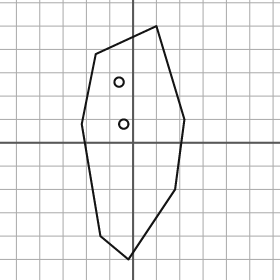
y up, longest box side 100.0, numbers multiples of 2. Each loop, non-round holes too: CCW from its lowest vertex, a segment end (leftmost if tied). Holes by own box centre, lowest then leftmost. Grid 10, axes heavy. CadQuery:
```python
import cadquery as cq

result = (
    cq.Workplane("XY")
    .moveTo(-2.0, -50.0)
    .lineTo(18.0, -20.0)
    .lineTo(22.0, 10.0)
    .lineTo(10.0, 50.0)
    .lineTo(-16.0, 38.0)
    .lineTo(-22.0, 8.0)
    .lineTo(-14.0, -40.0)
    .close()
    .moveTo(-4.0, 8.0)
    .circle(2.0)
    .moveTo(-6.0, 26.0)
    .circle(2.0)
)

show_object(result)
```